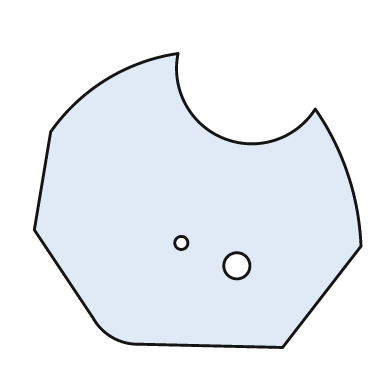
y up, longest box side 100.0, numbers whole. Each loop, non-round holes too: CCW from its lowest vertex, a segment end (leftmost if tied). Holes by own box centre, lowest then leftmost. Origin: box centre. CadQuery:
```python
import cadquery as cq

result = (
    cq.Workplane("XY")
    .moveTo(26.0, -45.0)
    .lineTo(50.0, -14.0)
    .threePointArc((46.0, 8.0), (36.0, 28.0))
    .threePointArc((8.0, 19.0), (-6.0, 45.0))
    .threePointArc((-28.0, 37.0), (-45.0, 21.0))
    .lineTo(-50.0, -9.0)
    .lineTo(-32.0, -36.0)
    .threePointArc((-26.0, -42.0), (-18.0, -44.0))
    .close()
    .moveTo(12.0, -20.0)
    .circle(4.0)
    .moveTo(-5.0, -13.0)
    .circle(2.0)
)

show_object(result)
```